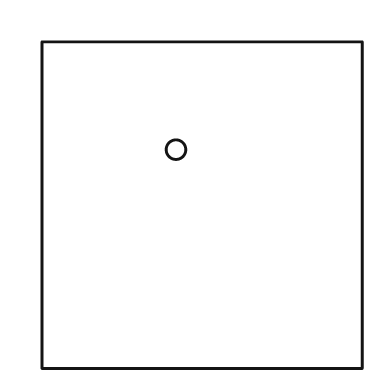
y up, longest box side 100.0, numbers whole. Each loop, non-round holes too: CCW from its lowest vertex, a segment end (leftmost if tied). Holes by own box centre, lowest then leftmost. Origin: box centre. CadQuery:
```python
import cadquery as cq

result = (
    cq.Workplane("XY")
    .moveTo(-49.0, -50.0)
    .lineTo(49.0, -50.0)
    .lineTo(49.0, 50.0)
    .lineTo(-49.0, 50.0)
    .close()
    .moveTo(-8.0, 17.0)
    .circle(3.0)
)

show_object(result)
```